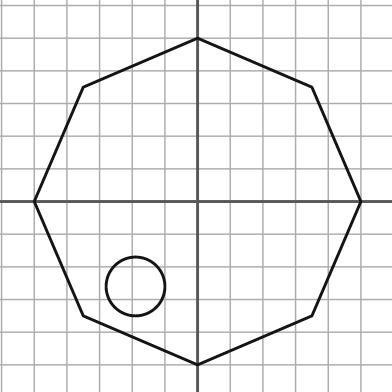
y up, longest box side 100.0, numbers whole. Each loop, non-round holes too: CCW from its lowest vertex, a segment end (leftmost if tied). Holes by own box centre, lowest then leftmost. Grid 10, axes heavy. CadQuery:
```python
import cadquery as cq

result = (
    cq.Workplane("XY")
    .moveTo(0.0, -50.0)
    .lineTo(35.0, -35.0)
    .lineTo(50.0, 0.0)
    .lineTo(35.0, 35.0)
    .lineTo(0.0, 50.0)
    .lineTo(-35.0, 35.0)
    .lineTo(-50.0, 0.0)
    .lineTo(-35.0, -35.0)
    .close()
    .moveTo(-19.0, -26.0)
    .circle(9.0)
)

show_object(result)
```